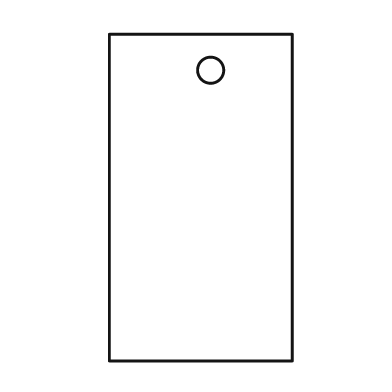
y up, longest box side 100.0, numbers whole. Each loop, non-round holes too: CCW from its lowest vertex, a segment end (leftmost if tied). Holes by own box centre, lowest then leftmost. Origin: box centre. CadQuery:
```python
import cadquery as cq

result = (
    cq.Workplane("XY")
    .moveTo(-28.0, -50.0)
    .lineTo(28.0, -50.0)
    .lineTo(28.0, 50.0)
    .lineTo(-28.0, 50.0)
    .close()
    .moveTo(3.0, 39.0)
    .circle(4.0)
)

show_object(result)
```